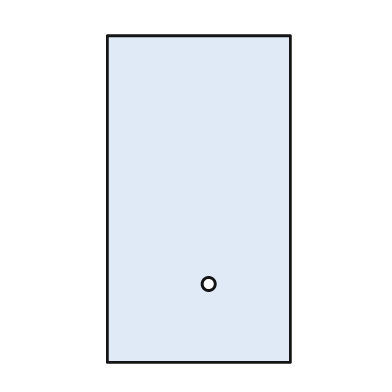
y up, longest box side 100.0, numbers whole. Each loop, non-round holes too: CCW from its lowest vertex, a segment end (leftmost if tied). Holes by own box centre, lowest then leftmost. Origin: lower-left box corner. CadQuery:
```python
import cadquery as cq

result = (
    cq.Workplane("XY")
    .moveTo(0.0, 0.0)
    .lineTo(56.0, 0.0)
    .lineTo(56.0, 100.0)
    .lineTo(0.0, 100.0)
    .close()
    .moveTo(31.0, 24.0)
    .circle(2.0)
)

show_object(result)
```